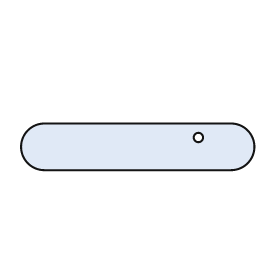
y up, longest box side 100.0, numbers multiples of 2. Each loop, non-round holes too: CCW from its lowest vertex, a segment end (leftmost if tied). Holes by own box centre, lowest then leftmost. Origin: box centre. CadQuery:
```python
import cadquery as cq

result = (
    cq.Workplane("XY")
    .moveTo(-40.0, -10.0)
    .lineTo(40.0, -10.0)
    .threePointArc((50.0, 0.0), (40.0, 10.0))
    .lineTo(-40.0, 10.0)
    .threePointArc((-50.0, 0.0), (-40.0, -10.0))
    .close()
    .moveTo(26.0, 4.0)
    .circle(2.0)
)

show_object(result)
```